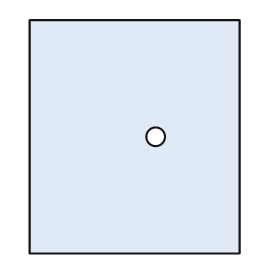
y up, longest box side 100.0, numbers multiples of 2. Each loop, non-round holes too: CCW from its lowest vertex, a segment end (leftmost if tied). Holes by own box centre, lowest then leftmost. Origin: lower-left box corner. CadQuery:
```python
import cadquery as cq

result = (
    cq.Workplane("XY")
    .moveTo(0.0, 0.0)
    .lineTo(90.0, 0.0)
    .lineTo(90.0, 100.0)
    .lineTo(0.0, 100.0)
    .close()
    .moveTo(54.0, 50.0)
    .circle(4.0)
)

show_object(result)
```